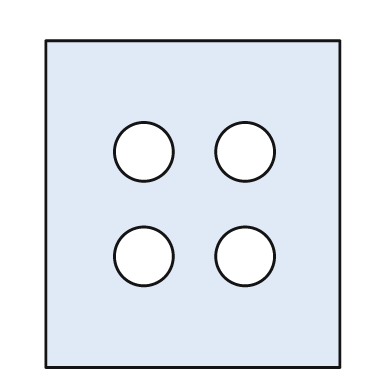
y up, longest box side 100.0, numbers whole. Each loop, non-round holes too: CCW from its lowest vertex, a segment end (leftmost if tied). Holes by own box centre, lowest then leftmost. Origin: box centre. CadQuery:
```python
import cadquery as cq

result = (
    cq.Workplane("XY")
    .moveTo(-45.0, -50.0)
    .lineTo(45.0, -50.0)
    .lineTo(45.0, 50.0)
    .lineTo(-45.0, 50.0)
    .close()
    .moveTo(-15.0, -16.0)
    .circle(9.0)
    .moveTo(16.0, -16.0)
    .circle(9.0)
    .moveTo(-15.0, 16.0)
    .circle(9.0)
    .moveTo(16.0, 16.0)
    .circle(9.0)
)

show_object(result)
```